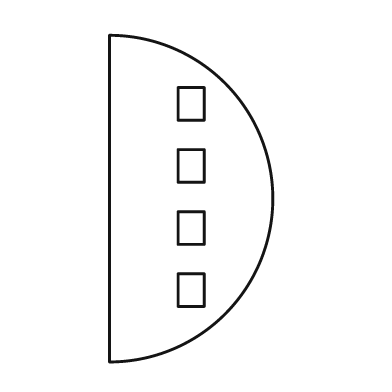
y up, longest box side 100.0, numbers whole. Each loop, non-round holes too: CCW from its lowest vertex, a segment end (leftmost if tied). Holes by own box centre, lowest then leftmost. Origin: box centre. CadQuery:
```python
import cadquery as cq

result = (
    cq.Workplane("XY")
    .moveTo(-25.0, -50.0)
    .threePointArc((25.0, 0.0), (-25.0, 50.0))
    .close()
    .moveTo(-4.0, -33.0)
    .lineTo(4.0, -33.0)
    .lineTo(4.0, -23.0)
    .lineTo(-4.0, -23.0)
    .close()
    .moveTo(-4.0, -14.0)
    .lineTo(4.0, -14.0)
    .lineTo(4.0, -4.0)
    .lineTo(-4.0, -4.0)
    .close()
    .moveTo(-4.0, 5.0)
    .lineTo(4.0, 5.0)
    .lineTo(4.0, 15.0)
    .lineTo(-4.0, 15.0)
    .close()
    .moveTo(-4.0, 24.0)
    .lineTo(4.0, 24.0)
    .lineTo(4.0, 34.0)
    .lineTo(-4.0, 34.0)
    .close()
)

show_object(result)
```